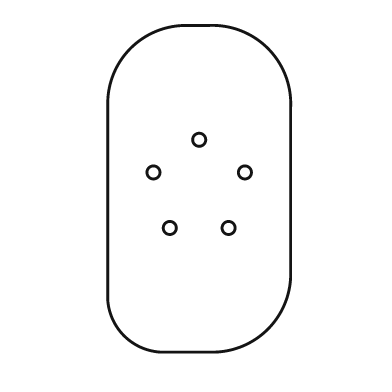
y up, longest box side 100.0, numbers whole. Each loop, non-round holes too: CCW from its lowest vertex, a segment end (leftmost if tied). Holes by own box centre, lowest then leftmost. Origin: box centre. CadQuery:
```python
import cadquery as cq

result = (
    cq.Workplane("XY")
    .moveTo(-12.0, -50.0)
    .lineTo(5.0, -50.0)
    .threePointArc((21.0, -43.0), (28.0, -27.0))
    .lineTo(28.0, 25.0)
    .threePointArc((21.0, 43.0), (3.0, 50.0))
    .lineTo(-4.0, 50.0)
    .threePointArc((-21.0, 43.0), (-28.0, 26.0))
    .lineTo(-28.0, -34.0)
    .threePointArc((-23.0, -45.0), (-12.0, -50.0))
    .close()
    .moveTo(-9.0, -12.0)
    .circle(2.0)
    .moveTo(9.0, -12.0)
    .circle(2.0)
    .moveTo(-14.0, 5.0)
    .circle(2.0)
    .moveTo(14.0, 5.0)
    .circle(2.0)
    .moveTo(0.0, 15.0)
    .circle(2.0)
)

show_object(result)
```